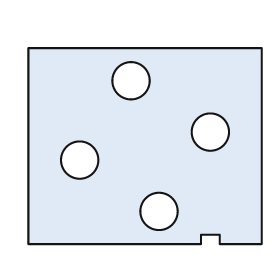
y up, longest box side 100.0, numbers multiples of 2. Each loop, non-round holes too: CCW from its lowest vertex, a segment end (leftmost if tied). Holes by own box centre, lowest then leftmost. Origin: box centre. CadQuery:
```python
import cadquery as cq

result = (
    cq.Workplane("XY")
    .moveTo(-50.0, -42.0)
    .lineTo(24.0, -42.0)
    .lineTo(24.0, -38.0)
    .lineTo(32.0, -38.0)
    .lineTo(32.0, -42.0)
    .lineTo(50.0, -42.0)
    .lineTo(50.0, 42.0)
    .lineTo(-50.0, 42.0)
    .close()
    .moveTo(6.0, -28.0)
    .circle(8.0)
    .moveTo(-28.0, -6.0)
    .circle(8.0)
    .moveTo(28.0, 6.0)
    .circle(8.0)
    .moveTo(-6.0, 28.0)
    .circle(8.0)
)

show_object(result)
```